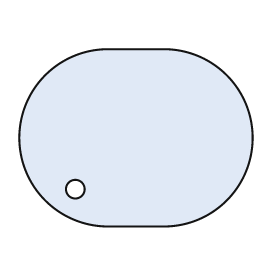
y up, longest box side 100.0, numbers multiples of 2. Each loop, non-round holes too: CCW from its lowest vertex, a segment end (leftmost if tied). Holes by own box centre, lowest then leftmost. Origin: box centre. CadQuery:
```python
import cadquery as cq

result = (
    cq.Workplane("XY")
    .moveTo(-12.0, -38.0)
    .lineTo(12.0, -38.0)
    .threePointArc((50.0, 0.0), (12.0, 38.0))
    .lineTo(-12.0, 38.0)
    .threePointArc((-50.0, 0.0), (-12.0, -38.0))
    .close()
    .moveTo(-26.0, -22.0)
    .circle(4.0)
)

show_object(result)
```